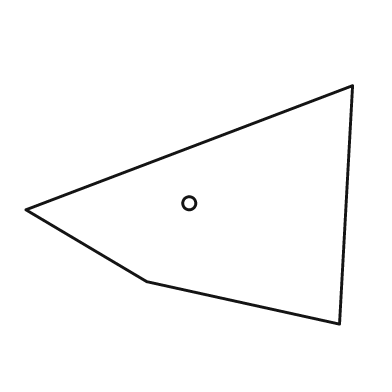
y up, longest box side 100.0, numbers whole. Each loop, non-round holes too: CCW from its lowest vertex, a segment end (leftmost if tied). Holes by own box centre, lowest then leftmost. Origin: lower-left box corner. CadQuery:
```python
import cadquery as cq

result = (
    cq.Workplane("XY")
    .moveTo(96.0, 0.0)
    .lineTo(100.0, 73.0)
    .lineTo(0.0, 35.0)
    .lineTo(37.0, 13.0)
    .close()
    .moveTo(50.0, 37.0)
    .circle(2.0)
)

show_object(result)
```